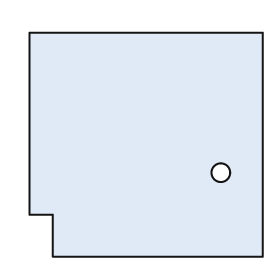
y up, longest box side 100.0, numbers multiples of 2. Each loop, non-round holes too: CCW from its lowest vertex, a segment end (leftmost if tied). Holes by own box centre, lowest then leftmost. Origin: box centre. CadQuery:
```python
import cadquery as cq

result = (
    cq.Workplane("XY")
    .moveTo(-40.0, -48.0)
    .lineTo(50.0, -48.0)
    .lineTo(50.0, 48.0)
    .lineTo(-50.0, 48.0)
    .lineTo(-50.0, -30.0)
    .lineTo(-40.0, -30.0)
    .close()
    .moveTo(32.0, -12.0)
    .circle(4.0)
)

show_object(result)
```